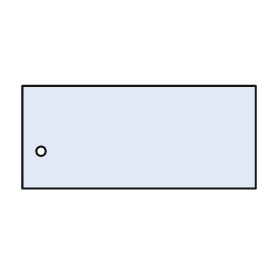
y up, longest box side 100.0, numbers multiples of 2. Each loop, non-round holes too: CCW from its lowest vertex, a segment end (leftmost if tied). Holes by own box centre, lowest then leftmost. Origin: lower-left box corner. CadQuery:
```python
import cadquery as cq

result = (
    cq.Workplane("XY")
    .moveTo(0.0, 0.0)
    .lineTo(100.0, 0.0)
    .lineTo(100.0, 44.0)
    .lineTo(0.0, 44.0)
    .close()
    .moveTo(8.0, 16.0)
    .circle(2.0)
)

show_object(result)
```